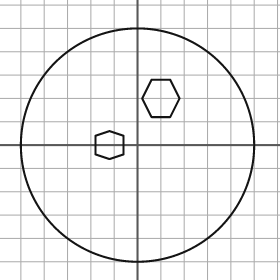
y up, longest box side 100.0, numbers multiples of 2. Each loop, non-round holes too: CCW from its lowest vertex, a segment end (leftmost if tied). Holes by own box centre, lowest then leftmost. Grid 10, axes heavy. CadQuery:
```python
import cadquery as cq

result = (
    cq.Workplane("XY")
    .moveTo(0.0, 0.0)
    .circle(50.0)
    .moveTo(-12.0, -6.0)
    .lineTo(-6.0, -4.0)
    .lineTo(-6.0, 4.0)
    .lineTo(-12.0, 6.0)
    .lineTo(-18.0, 4.0)
    .lineTo(-18.0, -4.0)
    .close()
    .moveTo(6.0, 12.0)
    .lineTo(14.0, 12.0)
    .lineTo(18.0, 20.0)
    .lineTo(14.0, 28.0)
    .lineTo(6.0, 28.0)
    .lineTo(2.0, 20.0)
    .close()
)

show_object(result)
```